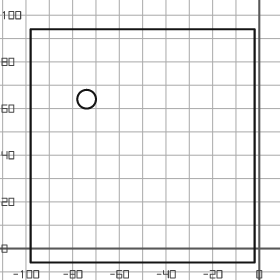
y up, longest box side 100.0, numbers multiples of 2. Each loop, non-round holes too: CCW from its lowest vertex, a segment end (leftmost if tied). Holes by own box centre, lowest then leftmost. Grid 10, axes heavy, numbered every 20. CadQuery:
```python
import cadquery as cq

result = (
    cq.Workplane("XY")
    .moveTo(-98.0, -6.0)
    .lineTo(-2.0, -6.0)
    .lineTo(-2.0, 94.0)
    .lineTo(-98.0, 94.0)
    .close()
    .moveTo(-74.0, 64.0)
    .circle(4.0)
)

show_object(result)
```